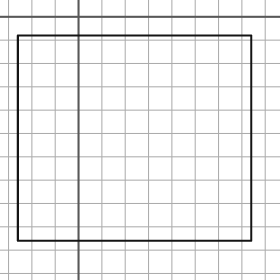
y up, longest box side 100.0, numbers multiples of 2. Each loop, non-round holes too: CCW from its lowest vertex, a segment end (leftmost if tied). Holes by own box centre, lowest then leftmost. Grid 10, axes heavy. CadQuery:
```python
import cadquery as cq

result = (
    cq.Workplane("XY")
    .moveTo(-26.0, -96.0)
    .lineTo(74.0, -96.0)
    .lineTo(74.0, -8.0)
    .lineTo(-26.0, -8.0)
    .close()
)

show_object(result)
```